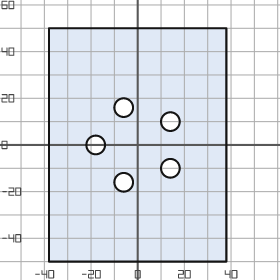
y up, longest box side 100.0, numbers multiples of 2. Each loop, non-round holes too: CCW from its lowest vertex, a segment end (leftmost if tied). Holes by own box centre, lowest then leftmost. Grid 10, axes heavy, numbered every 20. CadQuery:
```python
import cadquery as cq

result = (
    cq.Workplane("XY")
    .moveTo(-38.0, -50.0)
    .lineTo(38.0, -50.0)
    .lineTo(38.0, 50.0)
    .lineTo(-38.0, 50.0)
    .close()
    .moveTo(-6.0, -16.0)
    .circle(4.0)
    .moveTo(14.0, -10.0)
    .circle(4.0)
    .moveTo(-18.0, 0.0)
    .circle(4.0)
    .moveTo(14.0, 10.0)
    .circle(4.0)
    .moveTo(-6.0, 16.0)
    .circle(4.0)
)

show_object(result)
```